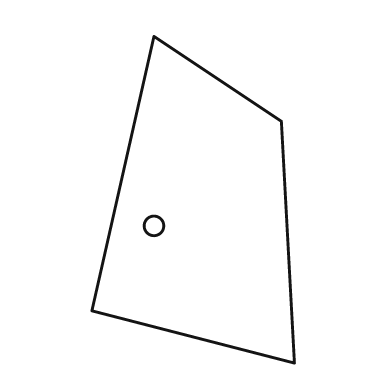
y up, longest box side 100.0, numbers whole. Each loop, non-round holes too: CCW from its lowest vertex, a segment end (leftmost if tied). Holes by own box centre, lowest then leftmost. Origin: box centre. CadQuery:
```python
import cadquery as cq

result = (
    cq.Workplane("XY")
    .moveTo(31.0, -50.0)
    .lineTo(27.0, 24.0)
    .lineTo(-12.0, 50.0)
    .lineTo(-31.0, -34.0)
    .close()
    .moveTo(-12.0, -8.0)
    .circle(3.0)
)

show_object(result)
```